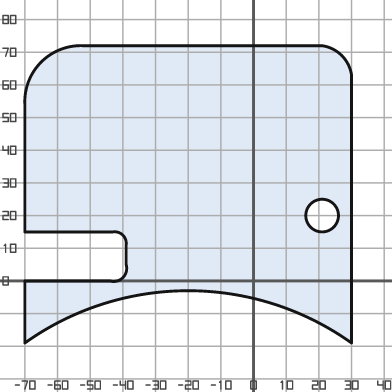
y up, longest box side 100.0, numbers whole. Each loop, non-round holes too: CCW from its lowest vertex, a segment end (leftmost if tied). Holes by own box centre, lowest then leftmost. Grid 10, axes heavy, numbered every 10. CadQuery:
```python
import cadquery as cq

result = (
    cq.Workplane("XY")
    .moveTo(-70.0, -19.0)
    .threePointArc((-20.0, -3.0), (30.0, -19.0))
    .lineTo(30.0, 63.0)
    .threePointArc((27.0, 69.0), (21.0, 72.0))
    .lineTo(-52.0, 72.0)
    .threePointArc((-65.0, 67.0), (-70.0, 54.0))
    .lineTo(-70.0, 15.0)
    .lineTo(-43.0, 15.0)
    .threePointArc((-40.0, 14.0), (-39.0, 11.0))
    .lineTo(-39.0, 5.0)
    .threePointArc((-40.0, 1.0), (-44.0, 0.0))
    .lineTo(-70.0, 0.0)
    .close()
    .moveTo(21.0, 20.0)
    .circle(5.0)
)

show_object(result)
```